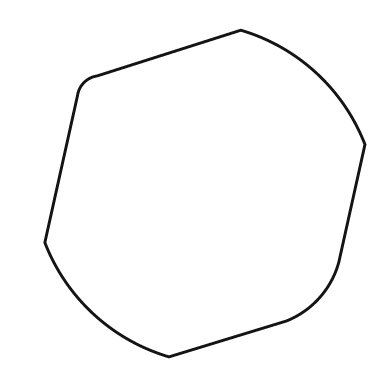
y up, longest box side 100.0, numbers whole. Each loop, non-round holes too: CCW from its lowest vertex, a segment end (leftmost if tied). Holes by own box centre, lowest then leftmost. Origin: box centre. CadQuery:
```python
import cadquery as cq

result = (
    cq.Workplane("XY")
    .moveTo(-11.0, -50.0)
    .lineTo(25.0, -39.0)
    .threePointArc((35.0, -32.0), (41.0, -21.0))
    .lineTo(49.0, 15.0)
    .threePointArc((34.0, 37.0), (11.0, 50.0))
    .lineTo(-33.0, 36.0)
    .threePointArc((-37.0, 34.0), (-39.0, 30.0))
    .lineTo(-49.0, -15.0)
    .threePointArc((-34.0, -37.0), (-11.0, -50.0))
    .close()
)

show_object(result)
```